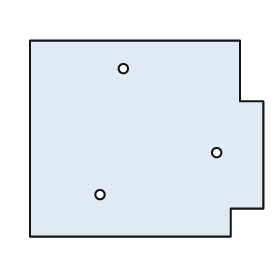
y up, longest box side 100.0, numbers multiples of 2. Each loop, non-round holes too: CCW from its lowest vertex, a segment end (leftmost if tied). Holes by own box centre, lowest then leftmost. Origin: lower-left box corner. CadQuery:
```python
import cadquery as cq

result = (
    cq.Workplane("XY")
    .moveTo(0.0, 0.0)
    .lineTo(86.0, 0.0)
    .lineTo(86.0, 12.0)
    .lineTo(100.0, 12.0)
    .lineTo(100.0, 58.0)
    .lineTo(90.0, 58.0)
    .lineTo(90.0, 84.0)
    .lineTo(0.0, 84.0)
    .close()
    .moveTo(30.0, 18.0)
    .circle(2.0)
    .moveTo(80.0, 36.0)
    .circle(2.0)
    .moveTo(40.0, 72.0)
    .circle(2.0)
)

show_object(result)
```